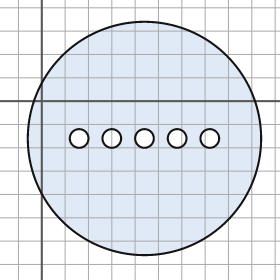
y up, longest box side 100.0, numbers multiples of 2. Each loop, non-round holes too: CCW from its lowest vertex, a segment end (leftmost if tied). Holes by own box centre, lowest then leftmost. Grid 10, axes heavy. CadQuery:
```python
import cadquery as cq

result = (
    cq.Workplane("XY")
    .moveTo(44.0, -16.0)
    .circle(50.0)
    .moveTo(16.0, -16.0)
    .circle(4.0)
    .moveTo(30.0, -16.0)
    .circle(4.0)
    .moveTo(44.0, -16.0)
    .circle(4.0)
    .moveTo(58.0, -16.0)
    .circle(4.0)
    .moveTo(72.0, -16.0)
    .circle(4.0)
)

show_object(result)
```